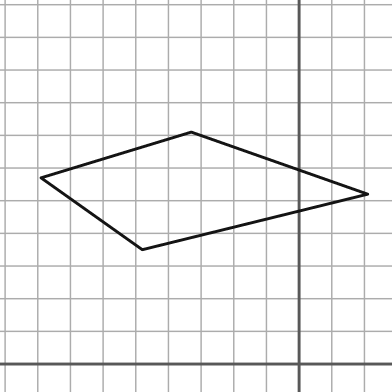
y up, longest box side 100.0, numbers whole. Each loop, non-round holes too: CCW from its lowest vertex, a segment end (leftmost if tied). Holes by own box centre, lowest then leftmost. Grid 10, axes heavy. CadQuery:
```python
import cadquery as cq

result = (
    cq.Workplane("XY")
    .moveTo(-48.0, 35.0)
    .lineTo(21.0, 52.0)
    .lineTo(-33.0, 71.0)
    .lineTo(-79.0, 57.0)
    .close()
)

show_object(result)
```